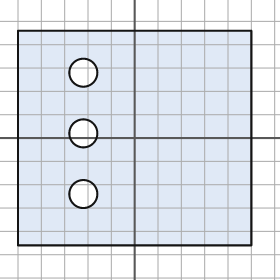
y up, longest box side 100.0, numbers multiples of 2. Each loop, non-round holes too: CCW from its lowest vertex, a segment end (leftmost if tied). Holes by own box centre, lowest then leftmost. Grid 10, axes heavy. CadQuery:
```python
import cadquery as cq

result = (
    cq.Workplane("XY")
    .moveTo(-50.0, -46.0)
    .lineTo(50.0, -46.0)
    .lineTo(50.0, 46.0)
    .lineTo(-50.0, 46.0)
    .close()
    .moveTo(-22.0, -24.0)
    .circle(6.0)
    .moveTo(-22.0, 2.0)
    .circle(6.0)
    .moveTo(-22.0, 28.0)
    .circle(6.0)
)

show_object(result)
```